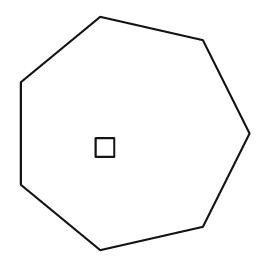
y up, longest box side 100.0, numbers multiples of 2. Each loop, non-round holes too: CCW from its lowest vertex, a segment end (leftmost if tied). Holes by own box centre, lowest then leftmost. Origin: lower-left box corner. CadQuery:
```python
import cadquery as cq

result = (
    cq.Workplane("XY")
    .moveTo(34.0, 0.0)
    .lineTo(78.0, 10.0)
    .lineTo(98.0, 50.0)
    .lineTo(78.0, 90.0)
    .lineTo(34.0, 100.0)
    .lineTo(0.0, 72.0)
    .lineTo(0.0, 28.0)
    .close()
    .moveTo(32.0, 40.0)
    .lineTo(40.0, 40.0)
    .lineTo(40.0, 48.0)
    .lineTo(32.0, 48.0)
    .close()
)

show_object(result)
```